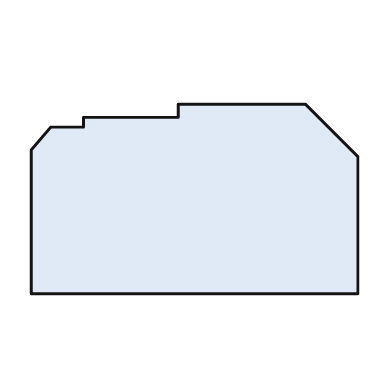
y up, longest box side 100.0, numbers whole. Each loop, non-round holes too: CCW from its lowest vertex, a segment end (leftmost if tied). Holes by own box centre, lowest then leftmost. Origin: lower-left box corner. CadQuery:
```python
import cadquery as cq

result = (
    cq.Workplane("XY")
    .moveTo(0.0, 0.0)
    .lineTo(100.0, 0.0)
    .lineTo(100.0, 42.0)
    .lineTo(84.0, 58.0)
    .lineTo(45.0, 58.0)
    .lineTo(45.0, 54.0)
    .lineTo(16.0, 54.0)
    .lineTo(16.0, 51.0)
    .lineTo(6.0, 51.0)
    .lineTo(0.0, 44.0)
    .close()
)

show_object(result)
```